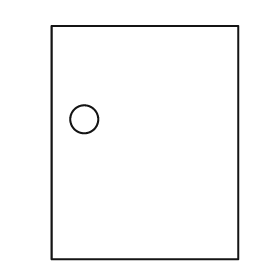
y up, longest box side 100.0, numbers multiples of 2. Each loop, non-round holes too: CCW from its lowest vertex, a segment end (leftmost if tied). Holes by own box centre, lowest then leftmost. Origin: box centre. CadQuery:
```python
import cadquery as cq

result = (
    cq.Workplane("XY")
    .moveTo(-40.0, -50.0)
    .lineTo(40.0, -50.0)
    .lineTo(40.0, 50.0)
    .lineTo(-40.0, 50.0)
    .close()
    .moveTo(-26.0, 10.0)
    .circle(6.0)
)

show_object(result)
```